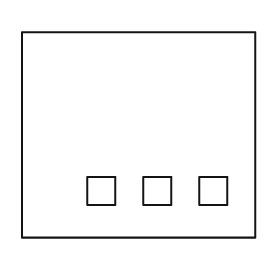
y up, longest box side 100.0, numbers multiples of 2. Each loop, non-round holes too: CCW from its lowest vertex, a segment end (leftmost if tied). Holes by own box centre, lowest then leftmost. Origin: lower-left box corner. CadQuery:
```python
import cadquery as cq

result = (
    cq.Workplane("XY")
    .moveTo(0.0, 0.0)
    .lineTo(100.0, 0.0)
    .lineTo(100.0, 88.0)
    .lineTo(0.0, 88.0)
    .close()
    .moveTo(28.0, 14.0)
    .lineTo(40.0, 14.0)
    .lineTo(40.0, 26.0)
    .lineTo(28.0, 26.0)
    .close()
    .moveTo(52.0, 14.0)
    .lineTo(64.0, 14.0)
    .lineTo(64.0, 26.0)
    .lineTo(52.0, 26.0)
    .close()
    .moveTo(76.0, 14.0)
    .lineTo(88.0, 14.0)
    .lineTo(88.0, 26.0)
    .lineTo(76.0, 26.0)
    .close()
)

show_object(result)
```